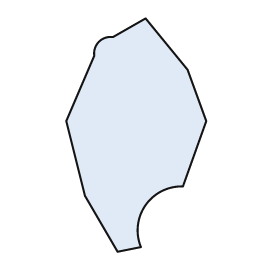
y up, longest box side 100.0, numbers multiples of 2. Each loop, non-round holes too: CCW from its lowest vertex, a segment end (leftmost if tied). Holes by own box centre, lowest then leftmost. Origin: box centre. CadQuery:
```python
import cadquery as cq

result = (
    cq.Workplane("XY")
    .moveTo(-8.0, -50.0)
    .lineTo(2.0, -48.0)
    .threePointArc((4.0, -30.0), (20.0, -22.0))
    .lineTo(30.0, 6.0)
    .lineTo(22.0, 28.0)
    .lineTo(4.0, 50.0)
    .lineTo(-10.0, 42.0)
    .threePointArc((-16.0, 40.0), (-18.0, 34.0))
    .lineTo(-30.0, 6.0)
    .lineTo(-22.0, -26.0)
    .close()
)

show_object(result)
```